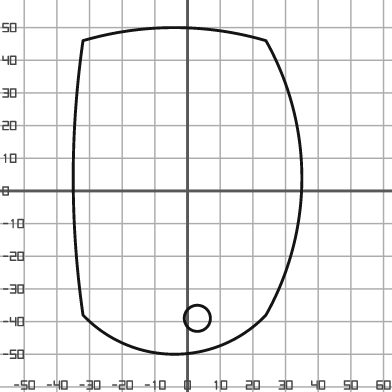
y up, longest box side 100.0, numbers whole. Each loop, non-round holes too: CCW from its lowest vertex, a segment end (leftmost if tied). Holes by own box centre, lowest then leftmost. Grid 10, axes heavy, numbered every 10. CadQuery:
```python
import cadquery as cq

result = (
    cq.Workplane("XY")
    .moveTo(-32.0, -38.0)
    .threePointArc((-4.0, -50.0), (24.0, -38.0))
    .threePointArc((35.0, 4.0), (24.0, 46.0))
    .threePointArc((-4.0, 50.0), (-32.0, 46.0))
    .threePointArc((-35.0, 4.0), (-32.0, -38.0))
    .close()
    .moveTo(3.0, -39.0)
    .circle(4.0)
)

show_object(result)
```